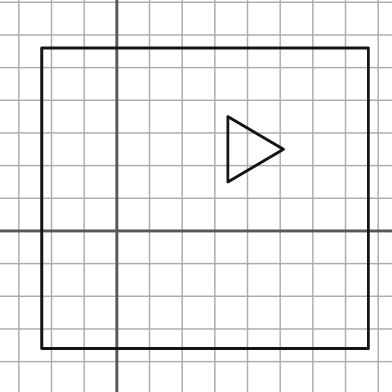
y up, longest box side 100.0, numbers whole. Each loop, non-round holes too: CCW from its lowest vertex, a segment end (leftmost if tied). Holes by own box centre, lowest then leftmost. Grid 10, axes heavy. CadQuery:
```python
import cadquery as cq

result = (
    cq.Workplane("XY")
    .moveTo(-23.0, -36.0)
    .lineTo(77.0, -36.0)
    .lineTo(77.0, 56.0)
    .lineTo(-23.0, 56.0)
    .close()
    .moveTo(34.0, 15.0)
    .lineTo(51.0, 25.0)
    .lineTo(34.0, 35.0)
    .close()
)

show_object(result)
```